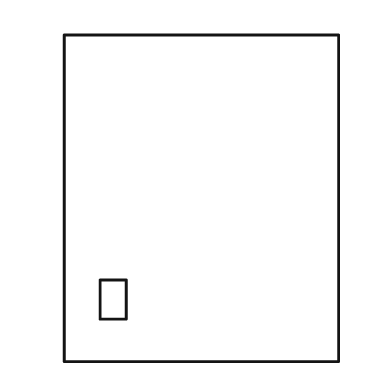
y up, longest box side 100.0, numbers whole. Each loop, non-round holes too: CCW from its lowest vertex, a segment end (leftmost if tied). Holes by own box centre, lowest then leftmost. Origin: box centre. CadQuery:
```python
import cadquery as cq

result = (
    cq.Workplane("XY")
    .moveTo(-42.0, -50.0)
    .lineTo(42.0, -50.0)
    .lineTo(42.0, 50.0)
    .lineTo(-42.0, 50.0)
    .close()
    .moveTo(-31.0, -37.0)
    .lineTo(-23.0, -37.0)
    .lineTo(-23.0, -25.0)
    .lineTo(-31.0, -25.0)
    .close()
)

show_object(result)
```